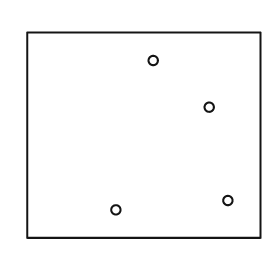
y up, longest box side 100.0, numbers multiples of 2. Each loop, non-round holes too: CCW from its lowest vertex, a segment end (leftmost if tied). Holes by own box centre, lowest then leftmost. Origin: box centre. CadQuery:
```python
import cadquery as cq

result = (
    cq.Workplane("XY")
    .moveTo(-50.0, -44.0)
    .lineTo(50.0, -44.0)
    .lineTo(50.0, 44.0)
    .lineTo(-50.0, 44.0)
    .close()
    .moveTo(-12.0, -32.0)
    .circle(2.0)
    .moveTo(36.0, -28.0)
    .circle(2.0)
    .moveTo(28.0, 12.0)
    .circle(2.0)
    .moveTo(4.0, 32.0)
    .circle(2.0)
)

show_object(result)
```